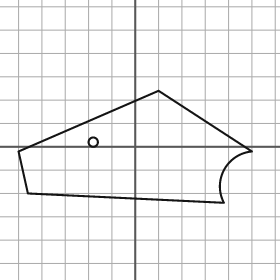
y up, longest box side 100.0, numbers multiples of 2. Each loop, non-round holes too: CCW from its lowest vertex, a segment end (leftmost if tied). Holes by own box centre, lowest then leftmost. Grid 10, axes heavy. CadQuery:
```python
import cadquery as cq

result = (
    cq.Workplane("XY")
    .moveTo(38.0, -24.0)
    .threePointArc((38.0, -10.0), (50.0, -2.0))
    .lineTo(10.0, 24.0)
    .lineTo(-50.0, -2.0)
    .lineTo(-46.0, -20.0)
    .close()
    .moveTo(-18.0, 2.0)
    .circle(2.0)
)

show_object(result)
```